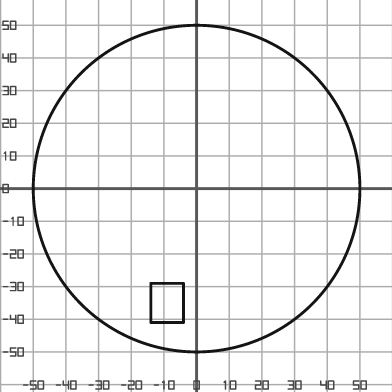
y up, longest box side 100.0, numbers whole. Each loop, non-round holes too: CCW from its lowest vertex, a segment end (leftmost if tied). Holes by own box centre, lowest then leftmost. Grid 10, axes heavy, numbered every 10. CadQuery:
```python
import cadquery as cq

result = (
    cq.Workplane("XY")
    .moveTo(0.0, 0.0)
    .circle(50.0)
    .moveTo(-14.0, -41.0)
    .lineTo(-4.0, -41.0)
    .lineTo(-4.0, -29.0)
    .lineTo(-14.0, -29.0)
    .close()
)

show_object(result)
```